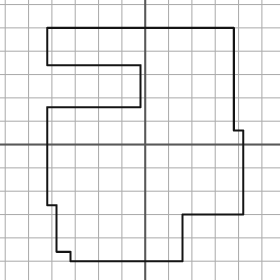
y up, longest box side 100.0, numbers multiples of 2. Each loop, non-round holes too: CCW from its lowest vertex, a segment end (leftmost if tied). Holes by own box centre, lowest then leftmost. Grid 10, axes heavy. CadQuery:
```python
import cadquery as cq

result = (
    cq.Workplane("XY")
    .moveTo(-32.0, -50.0)
    .lineTo(16.0, -50.0)
    .lineTo(16.0, -30.0)
    .lineTo(42.0, -30.0)
    .lineTo(42.0, 6.0)
    .lineTo(38.0, 6.0)
    .lineTo(38.0, 50.0)
    .lineTo(-42.0, 50.0)
    .lineTo(-42.0, 34.0)
    .lineTo(-2.0, 34.0)
    .lineTo(-2.0, 16.0)
    .lineTo(-42.0, 16.0)
    .lineTo(-42.0, -26.0)
    .lineTo(-38.0, -26.0)
    .lineTo(-38.0, -46.0)
    .lineTo(-32.0, -46.0)
    .close()
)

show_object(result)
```